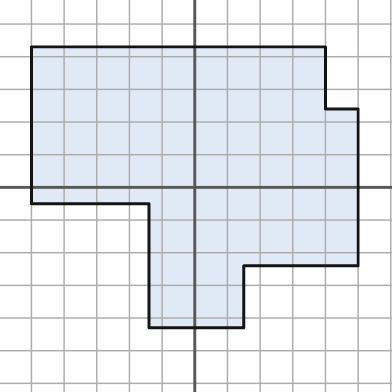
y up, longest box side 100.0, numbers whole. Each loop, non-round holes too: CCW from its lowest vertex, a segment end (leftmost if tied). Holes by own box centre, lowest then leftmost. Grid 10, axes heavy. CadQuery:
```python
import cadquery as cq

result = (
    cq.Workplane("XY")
    .moveTo(-14.0, -43.0)
    .lineTo(15.0, -43.0)
    .lineTo(15.0, -24.0)
    .lineTo(50.0, -24.0)
    .lineTo(50.0, 24.0)
    .lineTo(40.0, 24.0)
    .lineTo(40.0, 43.0)
    .lineTo(-50.0, 43.0)
    .lineTo(-50.0, -5.0)
    .lineTo(-14.0, -5.0)
    .close()
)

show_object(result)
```